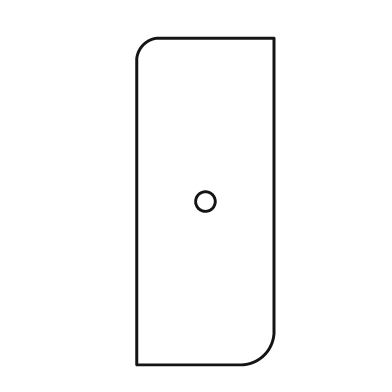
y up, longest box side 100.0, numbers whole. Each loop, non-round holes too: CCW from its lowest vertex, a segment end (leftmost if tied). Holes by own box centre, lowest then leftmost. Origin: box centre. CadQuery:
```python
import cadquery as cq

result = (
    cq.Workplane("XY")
    .moveTo(-21.0, -50.0)
    .lineTo(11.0, -50.0)
    .threePointArc((18.0, -47.0), (21.0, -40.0))
    .lineTo(21.0, 50.0)
    .lineTo(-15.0, 50.0)
    .threePointArc((-19.0, 48.0), (-21.0, 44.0))
    .close()
    .moveTo(0.0, 0.0)
    .circle(3.0)
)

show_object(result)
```